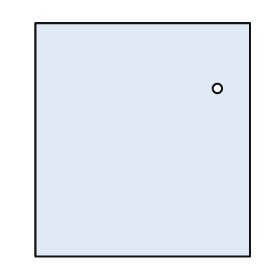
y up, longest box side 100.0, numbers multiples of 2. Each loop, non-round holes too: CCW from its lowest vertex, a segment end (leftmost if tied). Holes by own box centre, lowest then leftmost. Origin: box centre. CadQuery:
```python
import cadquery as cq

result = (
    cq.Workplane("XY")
    .moveTo(-46.0, -50.0)
    .lineTo(46.0, -50.0)
    .lineTo(46.0, 50.0)
    .lineTo(-46.0, 50.0)
    .close()
    .moveTo(32.0, 22.0)
    .circle(2.0)
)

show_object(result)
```